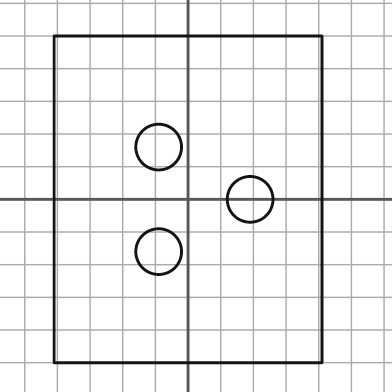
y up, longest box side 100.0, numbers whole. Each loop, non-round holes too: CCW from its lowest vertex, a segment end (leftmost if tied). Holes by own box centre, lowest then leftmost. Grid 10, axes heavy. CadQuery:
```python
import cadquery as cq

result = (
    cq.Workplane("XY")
    .moveTo(-41.0, -50.0)
    .lineTo(41.0, -50.0)
    .lineTo(41.0, 50.0)
    .lineTo(-41.0, 50.0)
    .close()
    .moveTo(-9.0, -16.0)
    .circle(7.0)
    .moveTo(19.0, 0.0)
    .circle(7.0)
    .moveTo(-9.0, 16.0)
    .circle(7.0)
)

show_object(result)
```